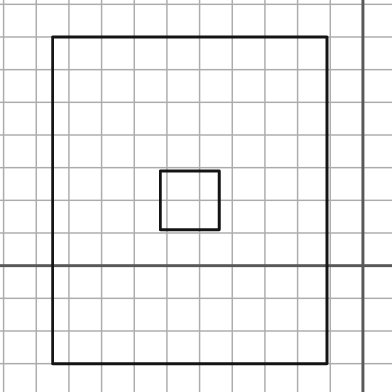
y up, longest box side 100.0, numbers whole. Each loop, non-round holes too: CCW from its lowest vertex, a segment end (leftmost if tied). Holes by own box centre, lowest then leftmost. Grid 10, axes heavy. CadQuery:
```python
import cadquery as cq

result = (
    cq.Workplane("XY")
    .moveTo(-95.0, -30.0)
    .lineTo(-11.0, -30.0)
    .lineTo(-11.0, 70.0)
    .lineTo(-95.0, 70.0)
    .close()
    .moveTo(-62.0, 11.0)
    .lineTo(-44.0, 11.0)
    .lineTo(-44.0, 29.0)
    .lineTo(-62.0, 29.0)
    .close()
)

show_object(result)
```